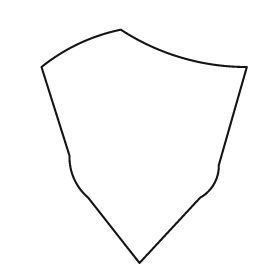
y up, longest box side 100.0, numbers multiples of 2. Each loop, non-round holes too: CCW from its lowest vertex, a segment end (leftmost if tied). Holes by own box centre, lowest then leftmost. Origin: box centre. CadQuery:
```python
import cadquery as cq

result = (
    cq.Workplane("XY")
    .moveTo(-2.0, -50.0)
    .lineTo(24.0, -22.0)
    .threePointArc((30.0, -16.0), (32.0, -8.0))
    .lineTo(44.0, 34.0)
    .threePointArc((16.0, 38.0), (-10.0, 50.0))
    .threePointArc((-28.0, 44.0), (-44.0, 34.0))
    .lineTo(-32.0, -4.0)
    .threePointArc((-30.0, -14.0), (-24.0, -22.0))
    .close()
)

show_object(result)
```